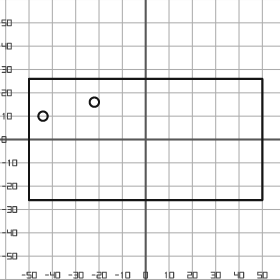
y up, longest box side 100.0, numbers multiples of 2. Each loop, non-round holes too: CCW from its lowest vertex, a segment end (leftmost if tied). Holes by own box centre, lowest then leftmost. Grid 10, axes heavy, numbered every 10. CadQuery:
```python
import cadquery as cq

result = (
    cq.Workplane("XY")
    .moveTo(-50.0, -26.0)
    .lineTo(50.0, -26.0)
    .lineTo(50.0, 26.0)
    .lineTo(-50.0, 26.0)
    .close()
    .moveTo(-44.0, 10.0)
    .circle(2.0)
    .moveTo(-22.0, 16.0)
    .circle(2.0)
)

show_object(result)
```